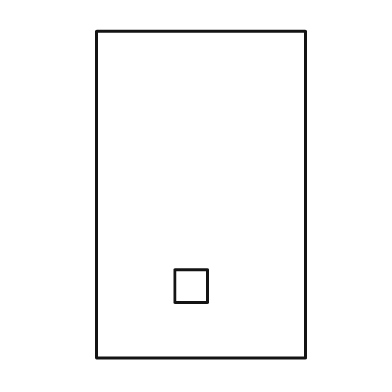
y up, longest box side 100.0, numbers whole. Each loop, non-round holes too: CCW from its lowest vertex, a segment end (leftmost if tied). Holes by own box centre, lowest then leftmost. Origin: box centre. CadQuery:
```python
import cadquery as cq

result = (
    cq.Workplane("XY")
    .moveTo(-32.0, -50.0)
    .lineTo(32.0, -50.0)
    .lineTo(32.0, 50.0)
    .lineTo(-32.0, 50.0)
    .close()
    .moveTo(-8.0, -33.0)
    .lineTo(2.0, -33.0)
    .lineTo(2.0, -23.0)
    .lineTo(-8.0, -23.0)
    .close()
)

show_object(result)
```